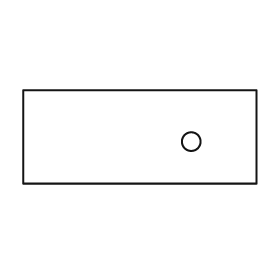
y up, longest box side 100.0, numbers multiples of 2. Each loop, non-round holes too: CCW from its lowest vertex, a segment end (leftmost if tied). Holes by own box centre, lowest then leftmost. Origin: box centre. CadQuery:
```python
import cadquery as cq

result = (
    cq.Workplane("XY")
    .moveTo(-50.0, -20.0)
    .lineTo(50.0, -20.0)
    .lineTo(50.0, 20.0)
    .lineTo(-50.0, 20.0)
    .close()
    .moveTo(22.0, -2.0)
    .circle(4.0)
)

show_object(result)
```